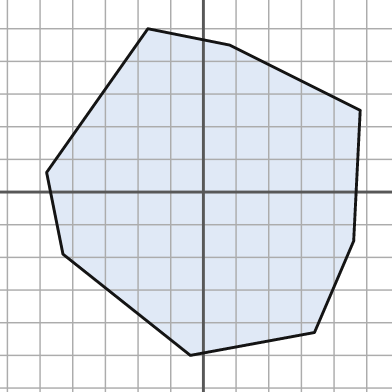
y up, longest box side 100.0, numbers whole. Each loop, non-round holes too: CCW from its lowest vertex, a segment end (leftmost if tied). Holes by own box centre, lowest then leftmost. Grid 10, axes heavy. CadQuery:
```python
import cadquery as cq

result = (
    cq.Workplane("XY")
    .moveTo(-4.0, -50.0)
    .lineTo(34.0, -43.0)
    .lineTo(46.0, -15.0)
    .lineTo(48.0, 25.0)
    .lineTo(8.0, 45.0)
    .lineTo(-17.0, 50.0)
    .lineTo(-48.0, 6.0)
    .lineTo(-43.0, -19.0)
    .close()
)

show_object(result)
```